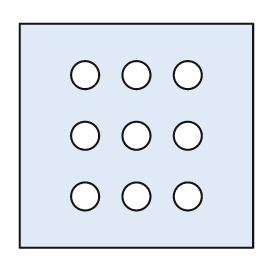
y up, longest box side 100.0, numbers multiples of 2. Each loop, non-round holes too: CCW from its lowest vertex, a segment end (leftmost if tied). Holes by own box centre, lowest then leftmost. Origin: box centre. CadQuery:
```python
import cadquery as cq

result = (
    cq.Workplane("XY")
    .moveTo(-50.0, -48.0)
    .lineTo(50.0, -48.0)
    .lineTo(50.0, 48.0)
    .lineTo(-50.0, 48.0)
    .close()
    .moveTo(-22.0, -26.0)
    .circle(6.0)
    .moveTo(0.0, -26.0)
    .circle(6.0)
    .moveTo(22.0, -26.0)
    .circle(6.0)
    .moveTo(-22.0, 0.0)
    .circle(6.0)
    .moveTo(0.0, 0.0)
    .circle(6.0)
    .moveTo(22.0, 0.0)
    .circle(6.0)
    .moveTo(-22.0, 26.0)
    .circle(6.0)
    .moveTo(0.0, 26.0)
    .circle(6.0)
    .moveTo(22.0, 26.0)
    .circle(6.0)
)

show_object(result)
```